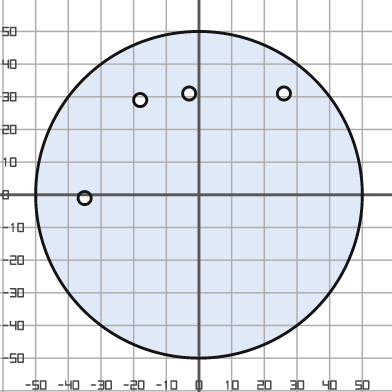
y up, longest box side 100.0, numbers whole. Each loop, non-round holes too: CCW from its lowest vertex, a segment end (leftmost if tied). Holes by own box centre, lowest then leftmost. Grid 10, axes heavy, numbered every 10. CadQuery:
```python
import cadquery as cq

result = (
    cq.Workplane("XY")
    .moveTo(0.0, 0.0)
    .circle(50.0)
    .moveTo(-35.0, -1.0)
    .circle(2.0)
    .moveTo(-18.0, 29.0)
    .circle(2.0)
    .moveTo(-3.0, 31.0)
    .circle(2.0)
    .moveTo(26.0, 31.0)
    .circle(2.0)
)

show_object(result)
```